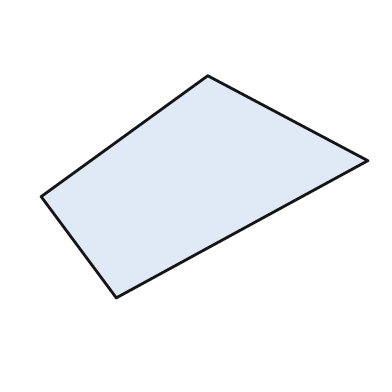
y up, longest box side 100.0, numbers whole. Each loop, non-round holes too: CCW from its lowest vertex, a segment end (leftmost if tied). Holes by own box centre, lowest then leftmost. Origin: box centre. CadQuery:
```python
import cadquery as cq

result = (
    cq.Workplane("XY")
    .moveTo(-27.0, -34.0)
    .lineTo(50.0, 8.0)
    .lineTo(1.0, 34.0)
    .lineTo(-50.0, -3.0)
    .close()
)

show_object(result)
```